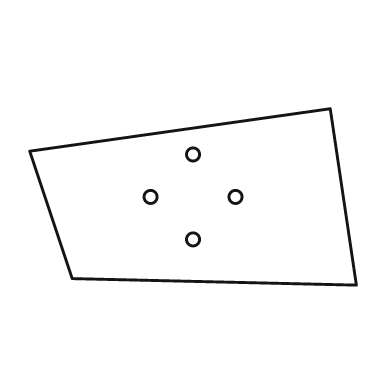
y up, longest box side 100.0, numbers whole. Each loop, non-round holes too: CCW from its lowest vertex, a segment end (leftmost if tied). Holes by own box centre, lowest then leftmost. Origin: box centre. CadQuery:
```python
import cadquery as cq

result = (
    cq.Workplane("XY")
    .moveTo(50.0, -27.0)
    .lineTo(42.0, 27.0)
    .lineTo(-50.0, 14.0)
    .lineTo(-37.0, -25.0)
    .close()
    .moveTo(0.0, -13.0)
    .circle(2.0)
    .moveTo(-13.0, 0.0)
    .circle(2.0)
    .moveTo(13.0, 0.0)
    .circle(2.0)
    .moveTo(0.0, 13.0)
    .circle(2.0)
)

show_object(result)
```